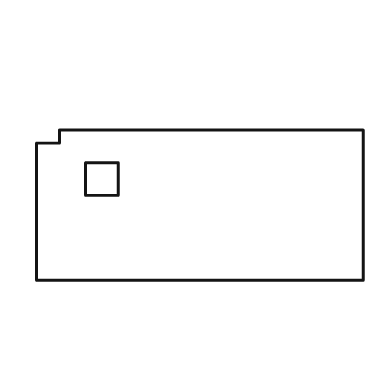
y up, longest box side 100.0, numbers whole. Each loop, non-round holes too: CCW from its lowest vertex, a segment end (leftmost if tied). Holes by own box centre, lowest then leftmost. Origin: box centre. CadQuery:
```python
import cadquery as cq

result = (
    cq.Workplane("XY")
    .moveTo(-50.0, -23.0)
    .lineTo(50.0, -23.0)
    .lineTo(50.0, 23.0)
    .lineTo(-43.0, 23.0)
    .lineTo(-43.0, 19.0)
    .lineTo(-50.0, 19.0)
    .close()
    .moveTo(-35.0, 3.0)
    .lineTo(-25.0, 3.0)
    .lineTo(-25.0, 13.0)
    .lineTo(-35.0, 13.0)
    .close()
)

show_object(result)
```